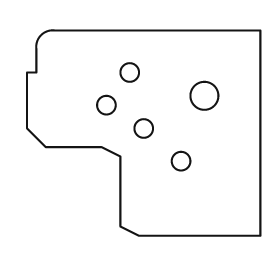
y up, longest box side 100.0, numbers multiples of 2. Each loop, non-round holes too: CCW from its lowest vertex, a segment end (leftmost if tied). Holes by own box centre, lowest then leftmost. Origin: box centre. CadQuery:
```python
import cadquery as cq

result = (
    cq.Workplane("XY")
    .moveTo(-2.0, -44.0)
    .lineTo(50.0, -44.0)
    .lineTo(50.0, 44.0)
    .lineTo(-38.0, 44.0)
    .threePointArc((-44.0, 42.0), (-46.0, 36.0))
    .lineTo(-46.0, 26.0)
    .lineTo(-50.0, 26.0)
    .lineTo(-50.0, 2.0)
    .lineTo(-42.0, -6.0)
    .lineTo(-18.0, -6.0)
    .lineTo(-10.0, -10.0)
    .lineTo(-10.0, -40.0)
    .close()
    .moveTo(16.0, -12.0)
    .circle(4.0)
    .moveTo(0.0, 2.0)
    .circle(4.0)
    .moveTo(-16.0, 12.0)
    .circle(4.0)
    .moveTo(26.0, 16.0)
    .circle(6.0)
    .moveTo(-6.0, 26.0)
    .circle(4.0)
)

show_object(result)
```